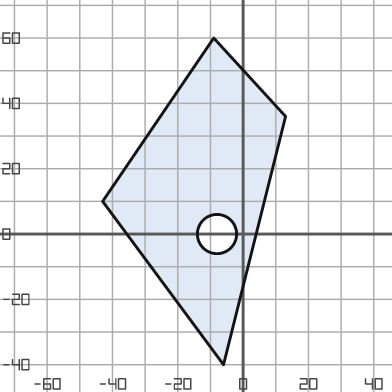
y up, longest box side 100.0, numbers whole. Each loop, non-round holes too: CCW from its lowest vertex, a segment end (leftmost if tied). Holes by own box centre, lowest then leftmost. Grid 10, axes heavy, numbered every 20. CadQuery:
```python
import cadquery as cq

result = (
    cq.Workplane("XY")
    .moveTo(-6.0, -40.0)
    .lineTo(13.0, 36.0)
    .lineTo(-9.0, 60.0)
    .lineTo(-43.0, 10.0)
    .close()
    .moveTo(-8.0, 0.0)
    .circle(6.0)
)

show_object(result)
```